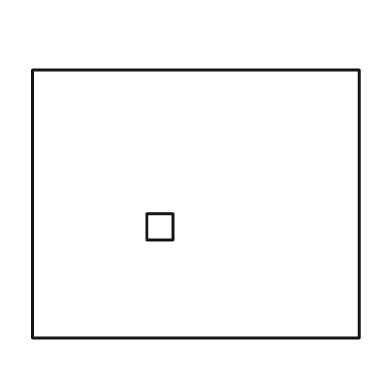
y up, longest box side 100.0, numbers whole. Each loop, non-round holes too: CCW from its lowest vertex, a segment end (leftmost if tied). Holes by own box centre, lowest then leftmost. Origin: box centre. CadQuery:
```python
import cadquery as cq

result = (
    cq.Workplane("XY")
    .moveTo(-50.0, -41.0)
    .lineTo(50.0, -41.0)
    .lineTo(50.0, 41.0)
    .lineTo(-50.0, 41.0)
    .close()
    .moveTo(-15.0, -11.0)
    .lineTo(-7.0, -11.0)
    .lineTo(-7.0, -3.0)
    .lineTo(-15.0, -3.0)
    .close()
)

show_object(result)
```